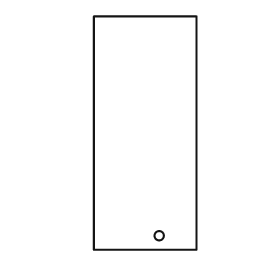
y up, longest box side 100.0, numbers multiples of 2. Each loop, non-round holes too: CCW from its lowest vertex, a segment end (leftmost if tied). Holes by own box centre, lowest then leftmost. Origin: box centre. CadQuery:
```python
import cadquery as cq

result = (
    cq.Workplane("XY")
    .moveTo(-22.0, -50.0)
    .lineTo(22.0, -50.0)
    .lineTo(22.0, 50.0)
    .lineTo(-22.0, 50.0)
    .close()
    .moveTo(6.0, -44.0)
    .circle(2.0)
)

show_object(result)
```